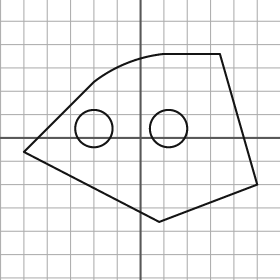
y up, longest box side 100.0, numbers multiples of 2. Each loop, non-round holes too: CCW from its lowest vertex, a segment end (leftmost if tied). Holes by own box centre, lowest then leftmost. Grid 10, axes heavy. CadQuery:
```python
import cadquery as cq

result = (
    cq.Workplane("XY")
    .moveTo(8.0, -36.0)
    .lineTo(50.0, -20.0)
    .lineTo(34.0, 36.0)
    .lineTo(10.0, 36.0)
    .threePointArc((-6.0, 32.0), (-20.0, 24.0))
    .lineTo(-50.0, -6.0)
    .close()
    .moveTo(-20.0, 4.0)
    .circle(8.0)
    .moveTo(12.0, 4.0)
    .circle(8.0)
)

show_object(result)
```